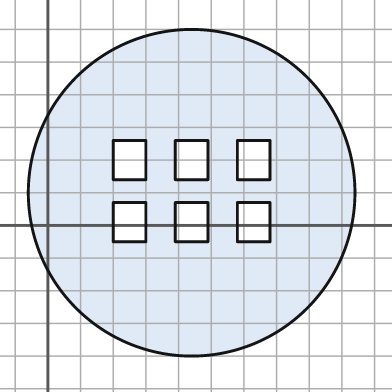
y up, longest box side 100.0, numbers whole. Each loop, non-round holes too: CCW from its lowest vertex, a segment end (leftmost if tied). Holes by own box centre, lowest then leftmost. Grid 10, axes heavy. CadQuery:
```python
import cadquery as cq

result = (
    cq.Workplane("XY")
    .moveTo(44.0, 10.0)
    .circle(50.0)
    .moveTo(20.0, -5.0)
    .lineTo(30.0, -5.0)
    .lineTo(30.0, 7.0)
    .lineTo(20.0, 7.0)
    .close()
    .moveTo(39.0, -5.0)
    .lineTo(49.0, -5.0)
    .lineTo(49.0, 7.0)
    .lineTo(39.0, 7.0)
    .close()
    .moveTo(58.0, -5.0)
    .lineTo(68.0, -5.0)
    .lineTo(68.0, 7.0)
    .lineTo(58.0, 7.0)
    .close()
    .moveTo(20.0, 14.0)
    .lineTo(30.0, 14.0)
    .lineTo(30.0, 26.0)
    .lineTo(20.0, 26.0)
    .close()
    .moveTo(39.0, 14.0)
    .lineTo(49.0, 14.0)
    .lineTo(49.0, 26.0)
    .lineTo(39.0, 26.0)
    .close()
    .moveTo(58.0, 14.0)
    .lineTo(68.0, 14.0)
    .lineTo(68.0, 26.0)
    .lineTo(58.0, 26.0)
    .close()
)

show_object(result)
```